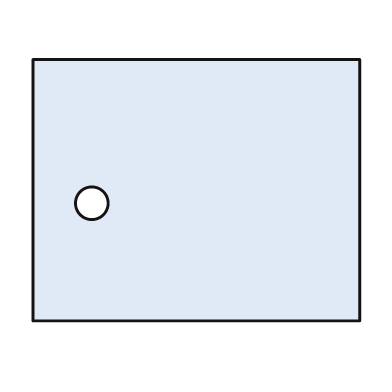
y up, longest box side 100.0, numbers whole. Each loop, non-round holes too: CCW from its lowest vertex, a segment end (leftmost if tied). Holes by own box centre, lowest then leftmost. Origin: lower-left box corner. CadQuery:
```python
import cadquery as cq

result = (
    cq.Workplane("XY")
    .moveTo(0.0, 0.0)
    .lineTo(100.0, 0.0)
    .lineTo(100.0, 80.0)
    .lineTo(0.0, 80.0)
    .close()
    .moveTo(18.0, 36.0)
    .circle(5.0)
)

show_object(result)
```